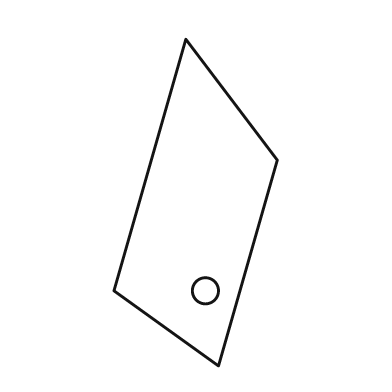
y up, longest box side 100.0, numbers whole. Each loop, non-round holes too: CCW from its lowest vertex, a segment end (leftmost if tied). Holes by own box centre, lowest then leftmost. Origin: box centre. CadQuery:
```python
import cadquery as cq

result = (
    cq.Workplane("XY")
    .moveTo(7.0, -50.0)
    .lineTo(25.0, 13.0)
    .lineTo(-3.0, 50.0)
    .lineTo(-25.0, -27.0)
    .close()
    .moveTo(3.0, -27.0)
    .circle(4.0)
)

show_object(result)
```